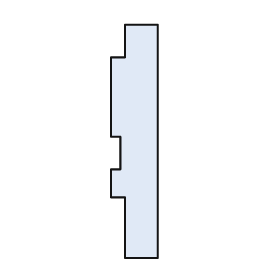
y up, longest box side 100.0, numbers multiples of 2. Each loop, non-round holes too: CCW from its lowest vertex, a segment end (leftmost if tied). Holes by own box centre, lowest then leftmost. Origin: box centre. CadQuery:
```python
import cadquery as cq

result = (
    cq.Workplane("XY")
    .moveTo(-4.0, -50.0)
    .lineTo(10.0, -50.0)
    .lineTo(10.0, 50.0)
    .lineTo(-4.0, 50.0)
    .lineTo(-4.0, 36.0)
    .lineTo(-10.0, 36.0)
    .lineTo(-10.0, 2.0)
    .lineTo(-6.0, 2.0)
    .lineTo(-6.0, -12.0)
    .lineTo(-10.0, -12.0)
    .lineTo(-10.0, -24.0)
    .lineTo(-4.0, -24.0)
    .close()
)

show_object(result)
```